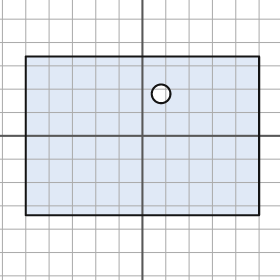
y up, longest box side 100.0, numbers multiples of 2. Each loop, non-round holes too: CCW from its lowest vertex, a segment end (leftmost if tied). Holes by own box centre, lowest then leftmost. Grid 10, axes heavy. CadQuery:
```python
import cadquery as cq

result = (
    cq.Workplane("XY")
    .moveTo(-50.0, -34.0)
    .lineTo(50.0, -34.0)
    .lineTo(50.0, 34.0)
    .lineTo(-50.0, 34.0)
    .close()
    .moveTo(8.0, 18.0)
    .circle(4.0)
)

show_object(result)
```